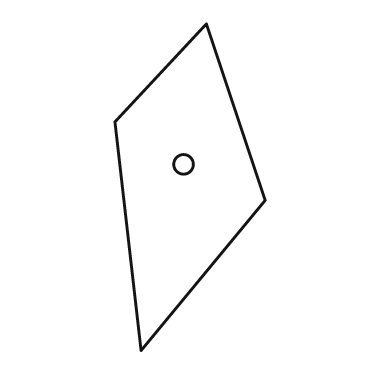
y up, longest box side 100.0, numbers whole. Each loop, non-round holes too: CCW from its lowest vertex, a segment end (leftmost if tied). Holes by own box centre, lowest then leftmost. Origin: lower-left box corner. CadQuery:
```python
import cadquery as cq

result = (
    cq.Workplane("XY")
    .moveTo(8.0, 0.0)
    .lineTo(46.0, 46.0)
    .lineTo(28.0, 100.0)
    .lineTo(0.0, 70.0)
    .close()
    .moveTo(21.0, 57.0)
    .circle(3.0)
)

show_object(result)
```